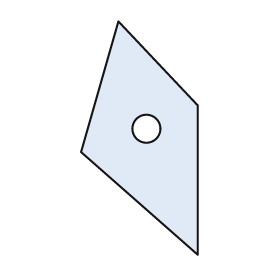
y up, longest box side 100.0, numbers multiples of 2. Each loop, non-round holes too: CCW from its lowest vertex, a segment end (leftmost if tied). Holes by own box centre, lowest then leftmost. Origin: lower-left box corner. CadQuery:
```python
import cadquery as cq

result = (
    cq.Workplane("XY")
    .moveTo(50.0, 0.0)
    .lineTo(50.0, 64.0)
    .lineTo(16.0, 100.0)
    .lineTo(0.0, 44.0)
    .close()
    .moveTo(28.0, 54.0)
    .circle(6.0)
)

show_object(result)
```